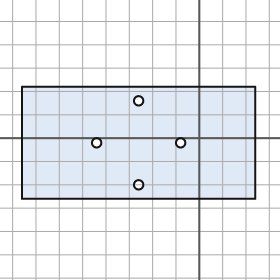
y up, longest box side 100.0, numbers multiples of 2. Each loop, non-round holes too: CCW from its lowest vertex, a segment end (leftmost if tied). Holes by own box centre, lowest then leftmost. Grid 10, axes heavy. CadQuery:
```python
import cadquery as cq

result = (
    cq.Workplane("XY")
    .moveTo(-76.0, -26.0)
    .lineTo(24.0, -26.0)
    .lineTo(24.0, 22.0)
    .lineTo(-76.0, 22.0)
    .close()
    .moveTo(-26.0, -20.0)
    .circle(2.0)
    .moveTo(-44.0, -2.0)
    .circle(2.0)
    .moveTo(-8.0, -2.0)
    .circle(2.0)
    .moveTo(-26.0, 16.0)
    .circle(2.0)
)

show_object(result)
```